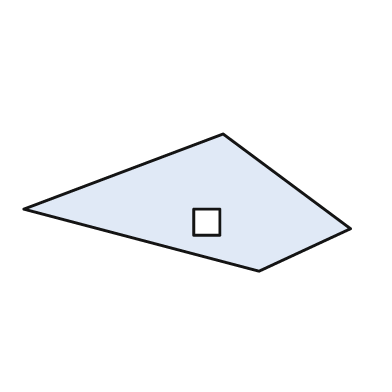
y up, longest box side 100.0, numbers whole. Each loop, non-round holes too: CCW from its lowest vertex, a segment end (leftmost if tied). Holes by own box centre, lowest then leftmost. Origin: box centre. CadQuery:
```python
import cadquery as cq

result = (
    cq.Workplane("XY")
    .moveTo(22.0, -21.0)
    .lineTo(50.0, -8.0)
    .lineTo(11.0, 21.0)
    .lineTo(-50.0, -2.0)
    .close()
    .moveTo(2.0, -10.0)
    .lineTo(10.0, -10.0)
    .lineTo(10.0, -2.0)
    .lineTo(2.0, -2.0)
    .close()
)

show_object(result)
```